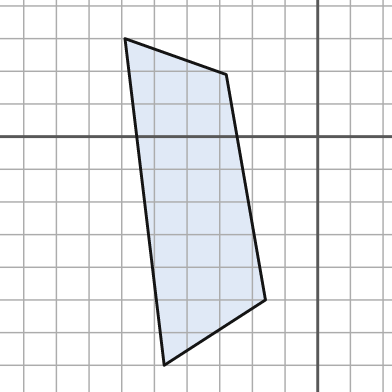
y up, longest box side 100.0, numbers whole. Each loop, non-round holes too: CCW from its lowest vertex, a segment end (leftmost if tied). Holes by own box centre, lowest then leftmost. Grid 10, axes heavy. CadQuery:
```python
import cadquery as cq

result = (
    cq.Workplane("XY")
    .moveTo(-47.0, -70.0)
    .lineTo(-16.0, -50.0)
    .lineTo(-28.0, 19.0)
    .lineTo(-59.0, 30.0)
    .close()
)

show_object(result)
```